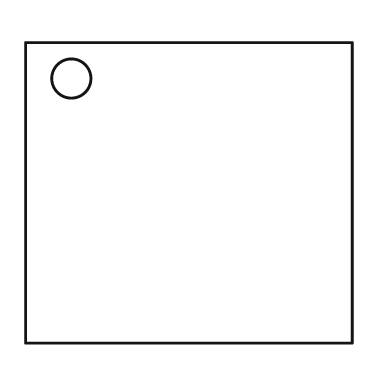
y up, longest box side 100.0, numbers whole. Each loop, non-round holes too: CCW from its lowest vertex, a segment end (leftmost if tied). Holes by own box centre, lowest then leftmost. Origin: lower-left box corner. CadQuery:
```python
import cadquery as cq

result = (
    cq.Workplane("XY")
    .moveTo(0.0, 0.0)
    .lineTo(100.0, 0.0)
    .lineTo(100.0, 92.0)
    .lineTo(0.0, 92.0)
    .close()
    .moveTo(14.0, 81.0)
    .circle(6.0)
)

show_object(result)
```